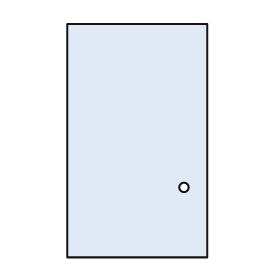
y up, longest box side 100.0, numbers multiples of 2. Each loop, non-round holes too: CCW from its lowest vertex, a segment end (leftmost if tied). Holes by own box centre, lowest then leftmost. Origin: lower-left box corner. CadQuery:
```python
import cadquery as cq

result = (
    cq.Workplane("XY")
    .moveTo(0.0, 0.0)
    .lineTo(60.0, 0.0)
    .lineTo(60.0, 100.0)
    .lineTo(0.0, 100.0)
    .close()
    .moveTo(50.0, 30.0)
    .circle(2.0)
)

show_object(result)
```